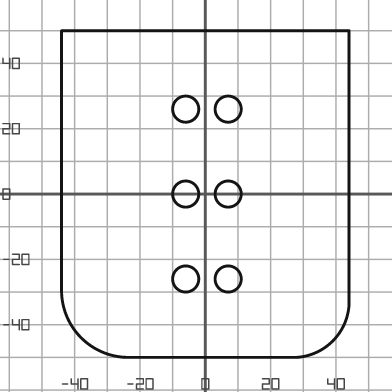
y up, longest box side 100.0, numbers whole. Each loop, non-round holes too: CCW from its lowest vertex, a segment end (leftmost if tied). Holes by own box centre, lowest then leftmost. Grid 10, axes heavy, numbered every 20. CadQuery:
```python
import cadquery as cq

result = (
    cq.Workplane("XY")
    .moveTo(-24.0, -50.0)
    .lineTo(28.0, -50.0)
    .threePointArc((39.0, -45.0), (44.0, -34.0))
    .lineTo(44.0, 50.0)
    .lineTo(-44.0, 50.0)
    .lineTo(-44.0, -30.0)
    .threePointArc((-38.0, -44.0), (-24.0, -50.0))
    .close()
    .moveTo(-6.0, -26.0)
    .circle(4.0)
    .moveTo(7.0, -26.0)
    .circle(4.0)
    .moveTo(-6.0, 0.0)
    .circle(4.0)
    .moveTo(7.0, 0.0)
    .circle(4.0)
    .moveTo(-6.0, 26.0)
    .circle(4.0)
    .moveTo(7.0, 26.0)
    .circle(4.0)
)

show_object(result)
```